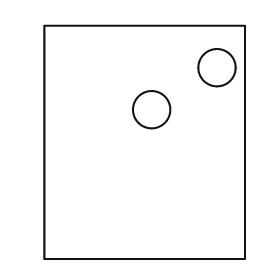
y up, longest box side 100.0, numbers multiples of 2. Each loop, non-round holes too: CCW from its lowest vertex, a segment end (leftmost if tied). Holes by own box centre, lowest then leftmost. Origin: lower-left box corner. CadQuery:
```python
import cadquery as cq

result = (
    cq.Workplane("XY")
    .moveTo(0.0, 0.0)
    .lineTo(86.0, 0.0)
    .lineTo(86.0, 100.0)
    .lineTo(0.0, 100.0)
    .close()
    .moveTo(46.0, 64.0)
    .circle(8.0)
    .moveTo(74.0, 82.0)
    .circle(8.0)
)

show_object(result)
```